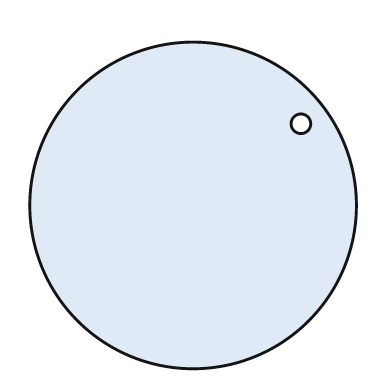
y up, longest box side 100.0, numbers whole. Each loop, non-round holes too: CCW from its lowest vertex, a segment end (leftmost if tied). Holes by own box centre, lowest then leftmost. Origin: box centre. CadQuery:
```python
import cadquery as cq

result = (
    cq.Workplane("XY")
    .moveTo(0.0, 0.0)
    .circle(50.0)
    .moveTo(33.0, 25.0)
    .circle(3.0)
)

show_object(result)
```